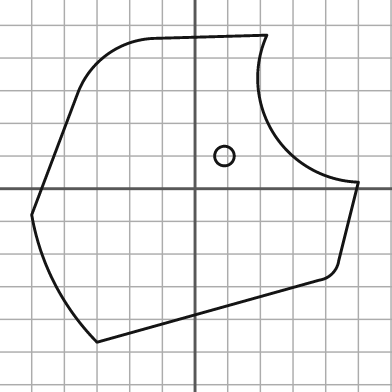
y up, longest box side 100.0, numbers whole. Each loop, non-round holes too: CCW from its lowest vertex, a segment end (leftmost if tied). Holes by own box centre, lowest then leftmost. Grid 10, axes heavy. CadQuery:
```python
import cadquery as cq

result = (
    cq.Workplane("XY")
    .moveTo(-30.0, -47.0)
    .lineTo(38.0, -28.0)
    .threePointArc((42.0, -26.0), (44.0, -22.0))
    .lineTo(50.0, 2.0)
    .threePointArc((24.0, 17.0), (22.0, 47.0))
    .lineTo(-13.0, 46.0)
    .threePointArc((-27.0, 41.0), (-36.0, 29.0))
    .lineTo(-50.0, -8.0)
    .threePointArc((-43.0, -29.0), (-30.0, -47.0))
    .close()
    .moveTo(9.0, 10.0)
    .circle(3.0)
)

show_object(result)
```